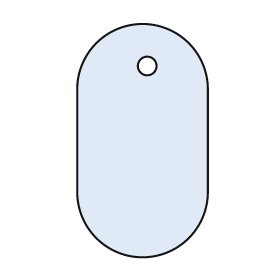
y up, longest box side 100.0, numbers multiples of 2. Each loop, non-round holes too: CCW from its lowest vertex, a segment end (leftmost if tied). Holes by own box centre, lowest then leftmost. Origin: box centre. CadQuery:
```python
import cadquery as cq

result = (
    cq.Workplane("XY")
    .moveTo(-28.0, -22.0)
    .threePointArc((0.0, -50.0), (28.0, -22.0))
    .lineTo(28.0, 22.0)
    .threePointArc((0.0, 50.0), (-28.0, 22.0))
    .close()
    .moveTo(2.0, 32.0)
    .circle(4.0)
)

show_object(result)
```